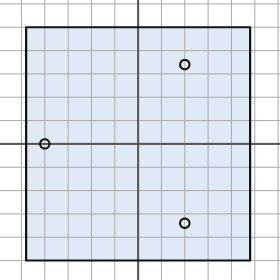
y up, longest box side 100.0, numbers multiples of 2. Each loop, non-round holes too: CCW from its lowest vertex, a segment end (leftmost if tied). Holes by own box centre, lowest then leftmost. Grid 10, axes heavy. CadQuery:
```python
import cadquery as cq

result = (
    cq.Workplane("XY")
    .moveTo(-48.0, -50.0)
    .lineTo(48.0, -50.0)
    .lineTo(48.0, 50.0)
    .lineTo(-48.0, 50.0)
    .close()
    .moveTo(20.0, -34.0)
    .circle(2.0)
    .moveTo(-40.0, 0.0)
    .circle(2.0)
    .moveTo(20.0, 34.0)
    .circle(2.0)
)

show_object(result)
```